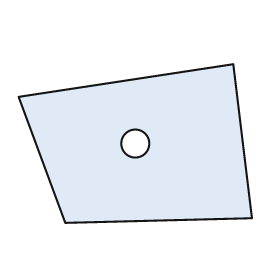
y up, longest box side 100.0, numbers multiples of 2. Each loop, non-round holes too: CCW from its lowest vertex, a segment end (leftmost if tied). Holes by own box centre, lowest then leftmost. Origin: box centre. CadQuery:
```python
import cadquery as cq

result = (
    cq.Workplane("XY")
    .moveTo(-30.0, -34.0)
    .lineTo(50.0, -32.0)
    .lineTo(42.0, 34.0)
    .lineTo(-50.0, 20.0)
    .close()
    .moveTo(0.0, 0.0)
    .circle(6.0)
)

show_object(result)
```